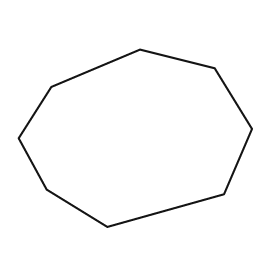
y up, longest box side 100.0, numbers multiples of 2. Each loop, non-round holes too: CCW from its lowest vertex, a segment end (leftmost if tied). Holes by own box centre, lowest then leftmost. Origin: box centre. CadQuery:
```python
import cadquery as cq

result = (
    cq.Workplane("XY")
    .moveTo(-12.0, -38.0)
    .lineTo(38.0, -24.0)
    .lineTo(50.0, 4.0)
    .lineTo(34.0, 30.0)
    .lineTo(2.0, 38.0)
    .lineTo(-36.0, 22.0)
    .lineTo(-50.0, 0.0)
    .lineTo(-38.0, -22.0)
    .close()
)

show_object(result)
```